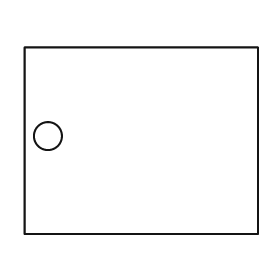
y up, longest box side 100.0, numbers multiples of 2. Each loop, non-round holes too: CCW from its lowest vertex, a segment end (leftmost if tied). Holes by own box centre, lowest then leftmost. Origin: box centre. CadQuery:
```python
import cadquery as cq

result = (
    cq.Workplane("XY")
    .moveTo(-50.0, -40.0)
    .lineTo(50.0, -40.0)
    .lineTo(50.0, 40.0)
    .lineTo(-50.0, 40.0)
    .close()
    .moveTo(-40.0, 2.0)
    .circle(6.0)
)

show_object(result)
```